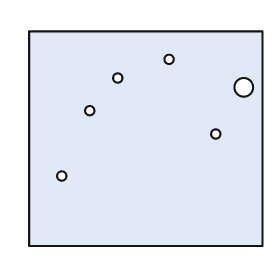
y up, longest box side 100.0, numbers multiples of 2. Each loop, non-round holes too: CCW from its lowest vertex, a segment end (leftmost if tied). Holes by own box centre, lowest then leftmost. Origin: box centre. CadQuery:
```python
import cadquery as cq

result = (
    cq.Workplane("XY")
    .moveTo(-50.0, -46.0)
    .lineTo(50.0, -46.0)
    .lineTo(50.0, 46.0)
    .lineTo(-50.0, 46.0)
    .close()
    .moveTo(-36.0, -16.0)
    .circle(2.0)
    .moveTo(30.0, 2.0)
    .circle(2.0)
    .moveTo(-24.0, 12.0)
    .circle(2.0)
    .moveTo(42.0, 22.0)
    .circle(4.0)
    .moveTo(-12.0, 26.0)
    .circle(2.0)
    .moveTo(10.0, 34.0)
    .circle(2.0)
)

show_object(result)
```